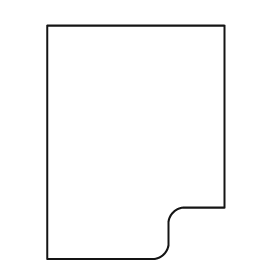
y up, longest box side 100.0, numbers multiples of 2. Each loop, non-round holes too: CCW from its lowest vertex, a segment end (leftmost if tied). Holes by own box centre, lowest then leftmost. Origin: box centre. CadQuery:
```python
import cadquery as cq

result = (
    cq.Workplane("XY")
    .moveTo(-38.0, -50.0)
    .lineTo(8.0, -50.0)
    .threePointArc((12.0, -48.0), (14.0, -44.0))
    .lineTo(14.0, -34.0)
    .threePointArc((16.0, -30.0), (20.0, -28.0))
    .lineTo(38.0, -28.0)
    .lineTo(38.0, 50.0)
    .lineTo(-38.0, 50.0)
    .close()
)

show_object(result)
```